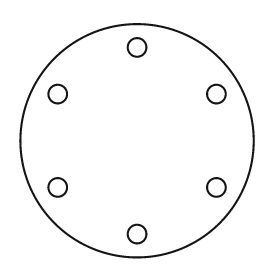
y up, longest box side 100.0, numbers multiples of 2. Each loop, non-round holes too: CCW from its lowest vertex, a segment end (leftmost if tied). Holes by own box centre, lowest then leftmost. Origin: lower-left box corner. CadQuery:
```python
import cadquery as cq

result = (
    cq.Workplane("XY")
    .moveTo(50.0, 50.0)
    .circle(50.0)
    .moveTo(50.0, 10.0)
    .circle(4.0)
    .moveTo(16.0, 30.0)
    .circle(4.0)
    .moveTo(84.0, 30.0)
    .circle(4.0)
    .moveTo(16.0, 70.0)
    .circle(4.0)
    .moveTo(84.0, 70.0)
    .circle(4.0)
    .moveTo(50.0, 90.0)
    .circle(4.0)
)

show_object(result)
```